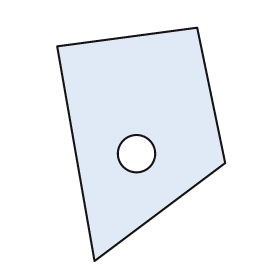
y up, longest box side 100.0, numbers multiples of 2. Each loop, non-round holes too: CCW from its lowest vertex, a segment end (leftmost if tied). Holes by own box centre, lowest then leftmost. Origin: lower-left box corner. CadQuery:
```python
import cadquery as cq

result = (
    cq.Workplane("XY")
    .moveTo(16.0, 0.0)
    .lineTo(72.0, 42.0)
    .lineTo(60.0, 100.0)
    .lineTo(0.0, 92.0)
    .close()
    .moveTo(34.0, 46.0)
    .circle(8.0)
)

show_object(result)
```